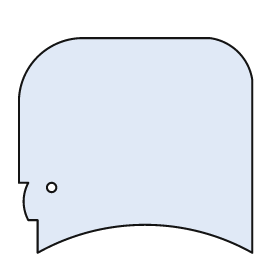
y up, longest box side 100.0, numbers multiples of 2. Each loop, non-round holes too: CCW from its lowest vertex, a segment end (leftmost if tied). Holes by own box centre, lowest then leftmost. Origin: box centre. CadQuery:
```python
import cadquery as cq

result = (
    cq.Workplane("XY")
    .moveTo(-42.0, -46.0)
    .threePointArc((4.0, -34.0), (50.0, -46.0))
    .lineTo(50.0, 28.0)
    .threePointArc((44.0, 40.0), (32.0, 46.0))
    .lineTo(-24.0, 46.0)
    .threePointArc((-42.0, 38.0), (-50.0, 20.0))
    .lineTo(-50.0, -16.0)
    .lineTo(-46.0, -16.0)
    .threePointArc((-48.0, -24.0), (-46.0, -32.0))
    .lineTo(-42.0, -32.0)
    .close()
    .moveTo(-36.0, -18.0)
    .circle(2.0)
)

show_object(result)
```